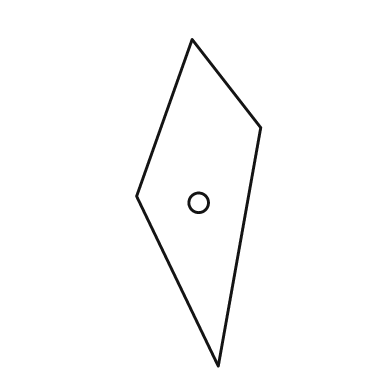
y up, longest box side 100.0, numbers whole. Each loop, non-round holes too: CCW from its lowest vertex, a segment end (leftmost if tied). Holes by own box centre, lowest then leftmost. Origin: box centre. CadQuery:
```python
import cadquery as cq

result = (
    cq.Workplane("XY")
    .moveTo(6.0, -50.0)
    .lineTo(19.0, 23.0)
    .lineTo(-2.0, 50.0)
    .lineTo(-19.0, 2.0)
    .close()
    .moveTo(0.0, 0.0)
    .circle(3.0)
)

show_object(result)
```